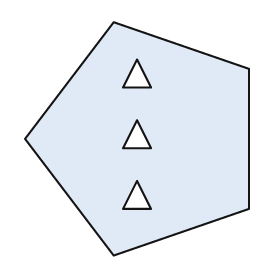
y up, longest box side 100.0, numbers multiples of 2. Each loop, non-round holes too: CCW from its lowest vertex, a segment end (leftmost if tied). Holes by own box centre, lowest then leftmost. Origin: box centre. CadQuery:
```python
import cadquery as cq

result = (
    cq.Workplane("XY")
    .moveTo(-10.0, -50.0)
    .lineTo(48.0, -30.0)
    .lineTo(48.0, 30.0)
    .lineTo(-10.0, 50.0)
    .lineTo(-48.0, 0.0)
    .close()
    .moveTo(-6.0, -30.0)
    .lineTo(6.0, -30.0)
    .lineTo(0.0, -18.0)
    .close()
    .moveTo(-6.0, -4.0)
    .lineTo(6.0, -4.0)
    .lineTo(0.0, 8.0)
    .close()
    .moveTo(-6.0, 22.0)
    .lineTo(6.0, 22.0)
    .lineTo(0.0, 34.0)
    .close()
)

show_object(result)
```